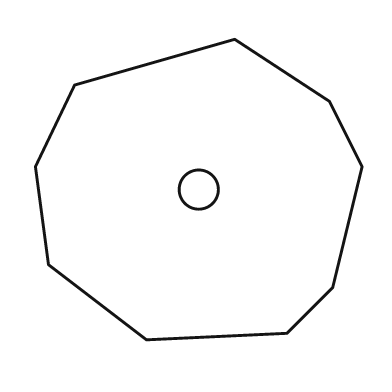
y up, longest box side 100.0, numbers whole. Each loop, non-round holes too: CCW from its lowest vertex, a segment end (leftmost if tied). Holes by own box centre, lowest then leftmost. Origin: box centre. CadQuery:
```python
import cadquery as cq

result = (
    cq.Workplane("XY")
    .moveTo(-16.0, -46.0)
    .lineTo(27.0, -44.0)
    .lineTo(41.0, -30.0)
    .lineTo(50.0, 7.0)
    .lineTo(40.0, 27.0)
    .lineTo(11.0, 46.0)
    .lineTo(-38.0, 32.0)
    .lineTo(-50.0, 7.0)
    .lineTo(-46.0, -23.0)
    .close()
    .moveTo(0.0, 0.0)
    .circle(6.0)
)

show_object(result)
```